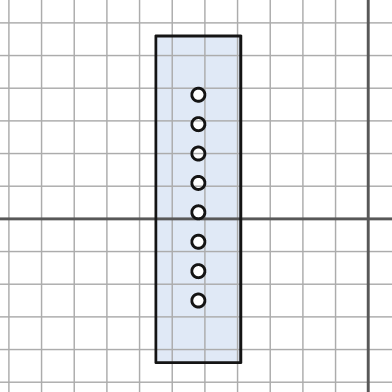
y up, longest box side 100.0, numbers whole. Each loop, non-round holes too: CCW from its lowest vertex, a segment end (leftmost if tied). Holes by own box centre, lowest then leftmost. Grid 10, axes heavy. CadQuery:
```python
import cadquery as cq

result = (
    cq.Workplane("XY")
    .moveTo(-65.0, -44.0)
    .lineTo(-39.0, -44.0)
    .lineTo(-39.0, 56.0)
    .lineTo(-65.0, 56.0)
    .close()
    .moveTo(-52.0, -25.0)
    .circle(2.0)
    .moveTo(-52.0, -16.0)
    .circle(2.0)
    .moveTo(-52.0, -7.0)
    .circle(2.0)
    .moveTo(-52.0, 2.0)
    .circle(2.0)
    .moveTo(-52.0, 11.0)
    .circle(2.0)
    .moveTo(-52.0, 20.0)
    .circle(2.0)
    .moveTo(-52.0, 29.0)
    .circle(2.0)
    .moveTo(-52.0, 38.0)
    .circle(2.0)
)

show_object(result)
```